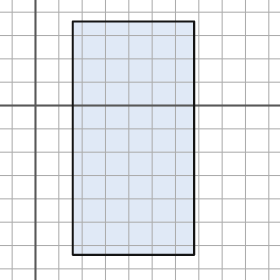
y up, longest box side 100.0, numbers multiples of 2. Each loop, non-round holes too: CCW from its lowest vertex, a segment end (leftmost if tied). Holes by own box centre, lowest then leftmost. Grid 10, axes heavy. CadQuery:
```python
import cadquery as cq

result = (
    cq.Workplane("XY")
    .moveTo(16.0, -64.0)
    .lineTo(68.0, -64.0)
    .lineTo(68.0, 36.0)
    .lineTo(16.0, 36.0)
    .close()
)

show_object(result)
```